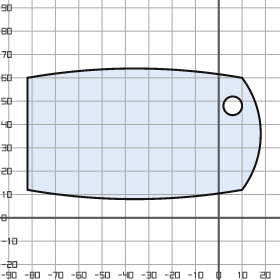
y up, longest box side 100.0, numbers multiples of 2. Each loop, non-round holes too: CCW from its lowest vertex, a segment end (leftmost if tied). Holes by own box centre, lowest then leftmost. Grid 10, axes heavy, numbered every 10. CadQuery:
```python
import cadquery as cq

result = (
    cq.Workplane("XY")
    .moveTo(-82.0, 12.0)
    .threePointArc((-36.0, 8.0), (10.0, 12.0))
    .threePointArc((18.0, 36.0), (10.0, 60.0))
    .threePointArc((-36.0, 64.0), (-82.0, 60.0))
    .close()
    .moveTo(6.0, 48.0)
    .circle(4.0)
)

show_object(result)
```